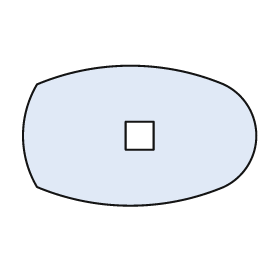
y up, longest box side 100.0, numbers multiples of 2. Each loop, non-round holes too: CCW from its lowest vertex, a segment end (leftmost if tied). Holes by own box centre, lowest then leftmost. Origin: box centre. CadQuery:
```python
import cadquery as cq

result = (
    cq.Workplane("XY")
    .moveTo(-44.0, -22.0)
    .threePointArc((-4.0, -30.0), (36.0, -22.0))
    .threePointArc((50.0, 0.0), (36.0, 22.0))
    .threePointArc((-4.0, 30.0), (-44.0, 22.0))
    .threePointArc((-50.0, 0.0), (-44.0, -22.0))
    .close()
    .moveTo(-6.0, -6.0)
    .lineTo(6.0, -6.0)
    .lineTo(6.0, 6.0)
    .lineTo(-6.0, 6.0)
    .close()
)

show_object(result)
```